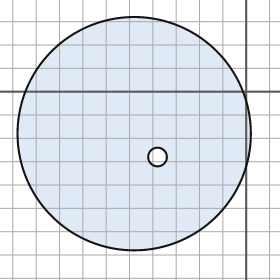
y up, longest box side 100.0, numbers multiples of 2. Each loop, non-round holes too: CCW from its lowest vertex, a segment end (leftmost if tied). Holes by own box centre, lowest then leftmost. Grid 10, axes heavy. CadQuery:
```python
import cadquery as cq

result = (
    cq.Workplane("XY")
    .moveTo(-48.0, -18.0)
    .circle(50.0)
    .moveTo(-38.0, -28.0)
    .circle(4.0)
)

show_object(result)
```